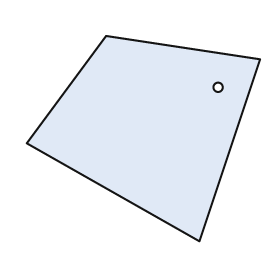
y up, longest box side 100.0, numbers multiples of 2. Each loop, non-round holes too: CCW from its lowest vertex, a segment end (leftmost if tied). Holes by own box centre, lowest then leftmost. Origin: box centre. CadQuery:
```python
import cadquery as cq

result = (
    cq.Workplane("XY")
    .moveTo(24.0, -44.0)
    .lineTo(50.0, 34.0)
    .lineTo(-16.0, 44.0)
    .lineTo(-50.0, -2.0)
    .close()
    .moveTo(32.0, 22.0)
    .circle(2.0)
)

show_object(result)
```